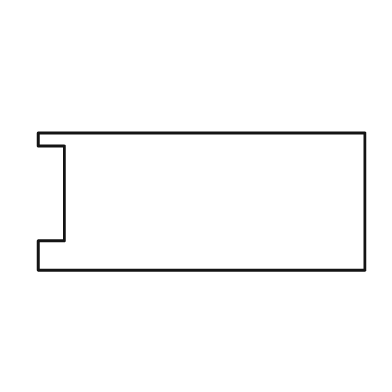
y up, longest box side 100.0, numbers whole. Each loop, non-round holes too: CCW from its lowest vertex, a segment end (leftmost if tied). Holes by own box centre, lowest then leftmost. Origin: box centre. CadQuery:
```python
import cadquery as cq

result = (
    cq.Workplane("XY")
    .moveTo(-50.0, -21.0)
    .lineTo(50.0, -21.0)
    .lineTo(50.0, 21.0)
    .lineTo(-50.0, 21.0)
    .lineTo(-50.0, 17.0)
    .lineTo(-42.0, 17.0)
    .lineTo(-42.0, -12.0)
    .lineTo(-50.0, -12.0)
    .close()
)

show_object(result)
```